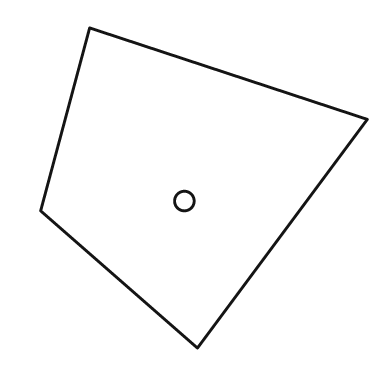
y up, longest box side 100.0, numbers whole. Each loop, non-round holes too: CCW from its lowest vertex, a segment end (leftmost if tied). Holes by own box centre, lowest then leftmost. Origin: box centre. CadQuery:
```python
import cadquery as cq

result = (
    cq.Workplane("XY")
    .moveTo(-2.0, -49.0)
    .lineTo(50.0, 21.0)
    .lineTo(-35.0, 49.0)
    .lineTo(-50.0, -7.0)
    .close()
    .moveTo(-6.0, -4.0)
    .circle(3.0)
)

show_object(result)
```